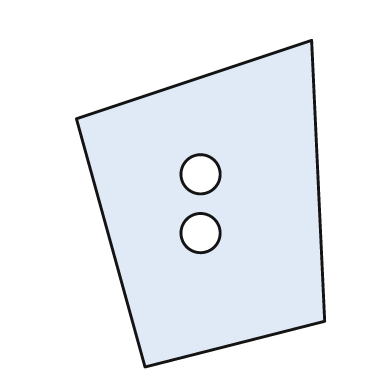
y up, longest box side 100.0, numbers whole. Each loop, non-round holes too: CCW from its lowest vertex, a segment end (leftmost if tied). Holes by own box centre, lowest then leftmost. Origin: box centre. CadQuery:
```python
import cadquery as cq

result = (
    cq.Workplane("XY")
    .moveTo(-17.0, -50.0)
    .lineTo(38.0, -36.0)
    .lineTo(34.0, 50.0)
    .lineTo(-38.0, 26.0)
    .close()
    .moveTo(0.0, -9.0)
    .circle(6.0)
    .moveTo(0.0, 9.0)
    .circle(6.0)
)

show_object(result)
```